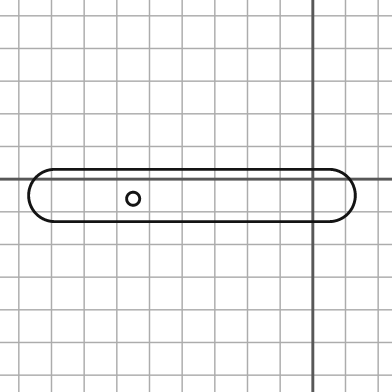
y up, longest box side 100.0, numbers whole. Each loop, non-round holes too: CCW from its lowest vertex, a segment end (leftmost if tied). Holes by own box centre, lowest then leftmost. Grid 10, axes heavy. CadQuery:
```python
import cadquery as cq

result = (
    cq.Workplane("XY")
    .moveTo(-79.0, -13.0)
    .lineTo(5.0, -13.0)
    .threePointArc((13.0, -5.0), (5.0, 3.0))
    .lineTo(-79.0, 3.0)
    .threePointArc((-87.0, -5.0), (-79.0, -13.0))
    .close()
    .moveTo(-55.0, -6.0)
    .circle(2.0)
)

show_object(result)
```